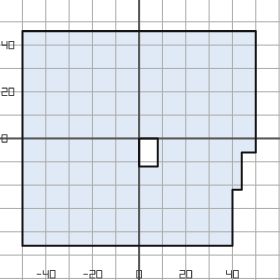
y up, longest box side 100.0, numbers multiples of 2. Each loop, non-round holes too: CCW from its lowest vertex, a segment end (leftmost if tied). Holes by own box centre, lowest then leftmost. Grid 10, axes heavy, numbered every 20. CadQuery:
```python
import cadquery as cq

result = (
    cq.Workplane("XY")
    .moveTo(-50.0, -46.0)
    .lineTo(40.0, -46.0)
    .lineTo(40.0, -22.0)
    .lineTo(44.0, -22.0)
    .lineTo(44.0, -6.0)
    .lineTo(50.0, -6.0)
    .lineTo(50.0, 46.0)
    .lineTo(-50.0, 46.0)
    .close()
    .moveTo(0.0, -12.0)
    .lineTo(8.0, -12.0)
    .lineTo(8.0, 0.0)
    .lineTo(0.0, 0.0)
    .close()
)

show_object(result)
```